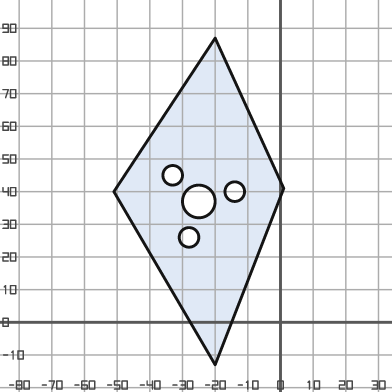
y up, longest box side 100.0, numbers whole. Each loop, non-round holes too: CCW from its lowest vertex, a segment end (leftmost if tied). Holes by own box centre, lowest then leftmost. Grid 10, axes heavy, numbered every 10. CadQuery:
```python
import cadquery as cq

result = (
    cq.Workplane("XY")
    .moveTo(-20.0, -13.0)
    .lineTo(1.0, 41.0)
    .lineTo(-20.0, 87.0)
    .lineTo(-51.0, 40.0)
    .close()
    .moveTo(-28.0, 26.0)
    .circle(3.0)
    .moveTo(-25.0, 37.0)
    .circle(5.0)
    .moveTo(-14.0, 40.0)
    .circle(3.0)
    .moveTo(-33.0, 45.0)
    .circle(3.0)
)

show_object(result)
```